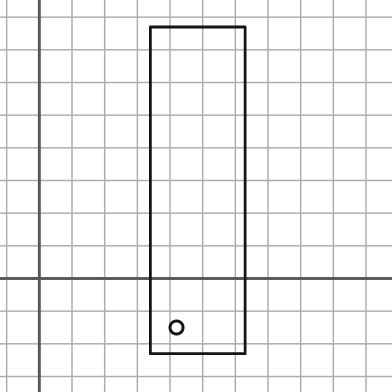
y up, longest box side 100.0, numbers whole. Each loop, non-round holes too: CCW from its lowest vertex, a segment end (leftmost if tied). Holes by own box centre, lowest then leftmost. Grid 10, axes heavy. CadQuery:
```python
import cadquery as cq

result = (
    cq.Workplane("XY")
    .moveTo(34.0, -23.0)
    .lineTo(63.0, -23.0)
    .lineTo(63.0, 77.0)
    .lineTo(34.0, 77.0)
    .close()
    .moveTo(42.0, -15.0)
    .circle(2.0)
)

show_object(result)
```